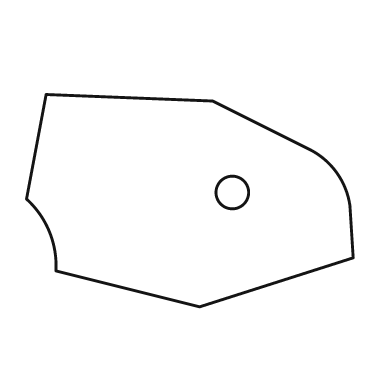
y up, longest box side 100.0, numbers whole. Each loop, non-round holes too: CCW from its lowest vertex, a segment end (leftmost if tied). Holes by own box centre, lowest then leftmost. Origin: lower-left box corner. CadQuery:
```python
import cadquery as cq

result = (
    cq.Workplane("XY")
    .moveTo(53.0, 0.0)
    .lineTo(100.0, 15.0)
    .lineTo(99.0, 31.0)
    .threePointArc((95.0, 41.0), (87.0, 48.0))
    .lineTo(57.0, 63.0)
    .lineTo(6.0, 65.0)
    .lineTo(0.0, 33.0)
    .threePointArc((7.0, 23.0), (9.0, 11.0))
    .close()
    .moveTo(63.0, 35.0)
    .circle(5.0)
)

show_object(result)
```